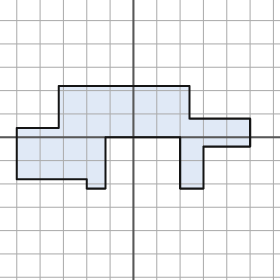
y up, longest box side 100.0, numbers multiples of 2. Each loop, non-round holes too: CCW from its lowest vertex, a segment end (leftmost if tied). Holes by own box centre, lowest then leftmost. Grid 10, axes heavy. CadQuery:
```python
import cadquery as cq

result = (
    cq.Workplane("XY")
    .moveTo(-20.0, -22.0)
    .lineTo(-12.0, -22.0)
    .lineTo(-12.0, 0.0)
    .lineTo(20.0, 0.0)
    .lineTo(20.0, -22.0)
    .lineTo(30.0, -22.0)
    .lineTo(30.0, -4.0)
    .lineTo(50.0, -4.0)
    .lineTo(50.0, 8.0)
    .lineTo(24.0, 8.0)
    .lineTo(24.0, 22.0)
    .lineTo(-32.0, 22.0)
    .lineTo(-32.0, 4.0)
    .lineTo(-50.0, 4.0)
    .lineTo(-50.0, -18.0)
    .lineTo(-20.0, -18.0)
    .close()
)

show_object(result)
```